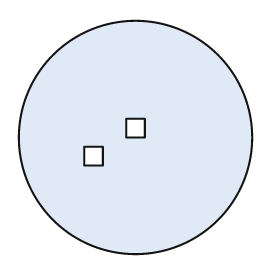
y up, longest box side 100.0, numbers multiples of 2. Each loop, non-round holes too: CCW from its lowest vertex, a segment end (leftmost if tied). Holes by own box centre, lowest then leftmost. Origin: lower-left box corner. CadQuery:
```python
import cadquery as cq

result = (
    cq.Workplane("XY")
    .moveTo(50.0, 50.0)
    .circle(50.0)
    .moveTo(28.0, 38.0)
    .lineTo(36.0, 38.0)
    .lineTo(36.0, 46.0)
    .lineTo(28.0, 46.0)
    .close()
    .moveTo(46.0, 50.0)
    .lineTo(54.0, 50.0)
    .lineTo(54.0, 58.0)
    .lineTo(46.0, 58.0)
    .close()
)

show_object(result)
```